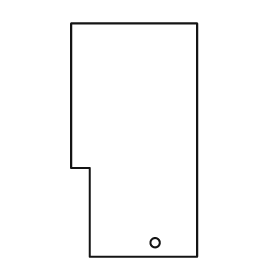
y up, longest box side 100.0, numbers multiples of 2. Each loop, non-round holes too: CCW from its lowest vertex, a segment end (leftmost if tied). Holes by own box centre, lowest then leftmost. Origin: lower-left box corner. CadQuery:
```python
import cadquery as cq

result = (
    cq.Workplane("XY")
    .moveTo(8.0, 0.0)
    .lineTo(54.0, 0.0)
    .lineTo(54.0, 100.0)
    .lineTo(0.0, 100.0)
    .lineTo(0.0, 38.0)
    .lineTo(8.0, 38.0)
    .close()
    .moveTo(36.0, 6.0)
    .circle(2.0)
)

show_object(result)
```